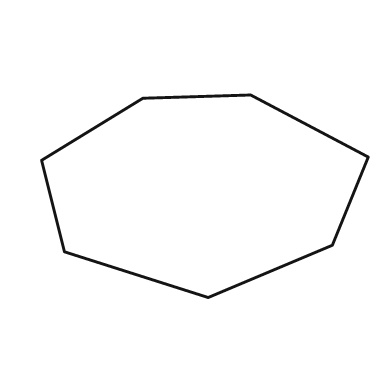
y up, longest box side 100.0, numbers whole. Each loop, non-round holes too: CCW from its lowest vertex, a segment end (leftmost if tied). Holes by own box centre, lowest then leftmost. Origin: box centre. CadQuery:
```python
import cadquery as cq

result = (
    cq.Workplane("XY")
    .moveTo(1.0, -31.0)
    .lineTo(39.0, -15.0)
    .lineTo(50.0, 12.0)
    .lineTo(14.0, 31.0)
    .lineTo(-19.0, 30.0)
    .lineTo(-50.0, 11.0)
    .lineTo(-43.0, -17.0)
    .close()
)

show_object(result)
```